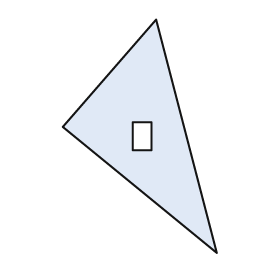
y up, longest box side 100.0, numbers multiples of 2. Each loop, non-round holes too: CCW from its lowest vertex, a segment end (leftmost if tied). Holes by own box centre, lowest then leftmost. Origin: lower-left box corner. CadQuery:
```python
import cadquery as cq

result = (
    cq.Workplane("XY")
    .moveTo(66.0, 0.0)
    .lineTo(40.0, 100.0)
    .lineTo(0.0, 54.0)
    .close()
    .moveTo(30.0, 44.0)
    .lineTo(38.0, 44.0)
    .lineTo(38.0, 56.0)
    .lineTo(30.0, 56.0)
    .close()
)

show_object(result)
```